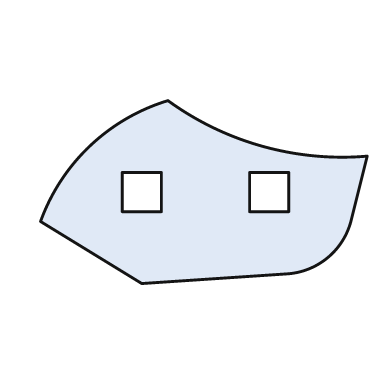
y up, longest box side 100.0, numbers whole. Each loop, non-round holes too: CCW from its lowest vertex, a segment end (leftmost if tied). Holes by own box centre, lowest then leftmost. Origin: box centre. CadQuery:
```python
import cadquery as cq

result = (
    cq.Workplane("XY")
    .moveTo(-19.0, -28.0)
    .lineTo(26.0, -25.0)
    .threePointArc((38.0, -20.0), (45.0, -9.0))
    .lineTo(50.0, 11.0)
    .threePointArc((18.0, 14.0), (-11.0, 28.0))
    .threePointArc((-35.0, 14.0), (-50.0, -9.0))
    .close()
    .moveTo(-25.0, -6.0)
    .lineTo(-13.0, -6.0)
    .lineTo(-13.0, 6.0)
    .lineTo(-25.0, 6.0)
    .close()
    .moveTo(14.0, -6.0)
    .lineTo(26.0, -6.0)
    .lineTo(26.0, 6.0)
    .lineTo(14.0, 6.0)
    .close()
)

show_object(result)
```